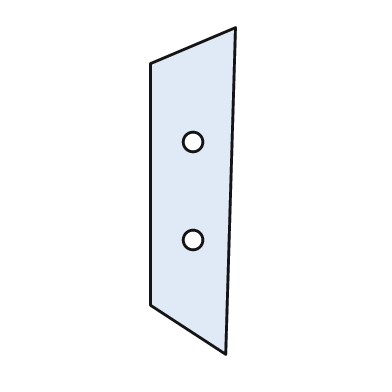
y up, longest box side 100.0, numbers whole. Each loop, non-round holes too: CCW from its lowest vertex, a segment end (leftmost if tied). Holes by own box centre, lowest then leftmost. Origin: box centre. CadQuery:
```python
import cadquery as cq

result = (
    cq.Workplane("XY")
    .moveTo(10.0, -50.0)
    .lineTo(13.0, 50.0)
    .lineTo(-13.0, 39.0)
    .lineTo(-13.0, -35.0)
    .close()
    .moveTo(0.0, -15.0)
    .circle(3.0)
    .moveTo(0.0, 15.0)
    .circle(3.0)
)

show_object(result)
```